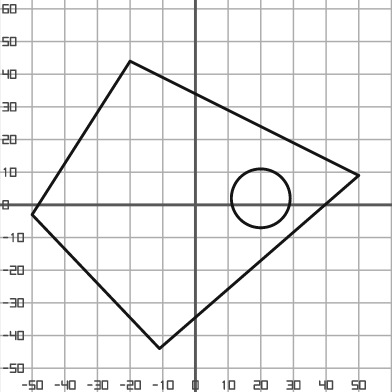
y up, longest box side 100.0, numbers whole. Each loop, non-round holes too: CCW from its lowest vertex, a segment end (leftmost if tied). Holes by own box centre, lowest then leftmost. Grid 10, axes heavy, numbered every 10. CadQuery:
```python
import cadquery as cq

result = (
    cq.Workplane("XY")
    .moveTo(-11.0, -44.0)
    .lineTo(50.0, 9.0)
    .lineTo(-20.0, 44.0)
    .lineTo(-50.0, -3.0)
    .close()
    .moveTo(20.0, 2.0)
    .circle(9.0)
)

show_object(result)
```